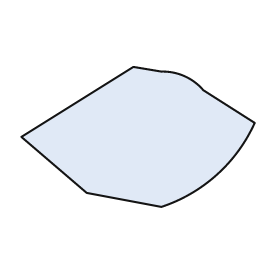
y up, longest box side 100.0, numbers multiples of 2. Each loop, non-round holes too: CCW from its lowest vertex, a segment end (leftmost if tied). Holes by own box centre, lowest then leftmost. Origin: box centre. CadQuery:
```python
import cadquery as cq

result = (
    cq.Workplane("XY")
    .moveTo(10.0, -30.0)
    .threePointArc((34.0, -16.0), (50.0, 6.0))
    .lineTo(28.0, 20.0)
    .threePointArc((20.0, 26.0), (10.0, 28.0))
    .lineTo(-2.0, 30.0)
    .lineTo(-50.0, 0.0)
    .lineTo(-22.0, -24.0)
    .close()
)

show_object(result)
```